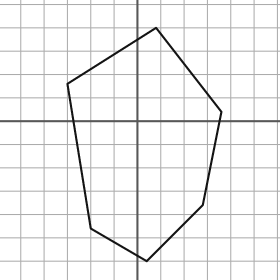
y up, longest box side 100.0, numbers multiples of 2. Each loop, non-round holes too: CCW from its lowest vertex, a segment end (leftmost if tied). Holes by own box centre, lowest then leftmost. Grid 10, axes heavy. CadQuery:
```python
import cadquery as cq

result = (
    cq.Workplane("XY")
    .moveTo(4.0, -60.0)
    .lineTo(28.0, -36.0)
    .lineTo(36.0, 4.0)
    .lineTo(8.0, 40.0)
    .lineTo(-30.0, 16.0)
    .lineTo(-20.0, -46.0)
    .close()
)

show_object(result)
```